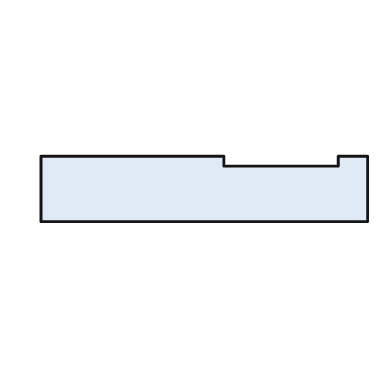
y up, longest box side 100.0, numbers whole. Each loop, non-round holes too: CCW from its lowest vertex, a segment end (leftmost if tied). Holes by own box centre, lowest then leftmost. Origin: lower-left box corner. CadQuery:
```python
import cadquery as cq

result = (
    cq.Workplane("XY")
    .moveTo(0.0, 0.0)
    .lineTo(100.0, 0.0)
    .lineTo(100.0, 20.0)
    .lineTo(91.0, 20.0)
    .lineTo(91.0, 17.0)
    .lineTo(56.0, 17.0)
    .lineTo(56.0, 20.0)
    .lineTo(0.0, 20.0)
    .close()
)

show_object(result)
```